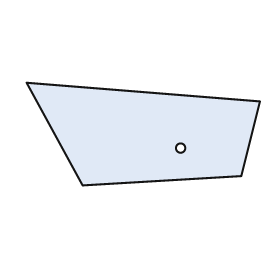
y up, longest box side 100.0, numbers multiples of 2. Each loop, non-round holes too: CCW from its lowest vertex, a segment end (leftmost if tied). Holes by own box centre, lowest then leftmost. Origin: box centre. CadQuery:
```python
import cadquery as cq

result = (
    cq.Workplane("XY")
    .moveTo(-26.0, -22.0)
    .lineTo(42.0, -18.0)
    .lineTo(50.0, 14.0)
    .lineTo(-50.0, 22.0)
    .close()
    .moveTo(16.0, -6.0)
    .circle(2.0)
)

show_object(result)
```